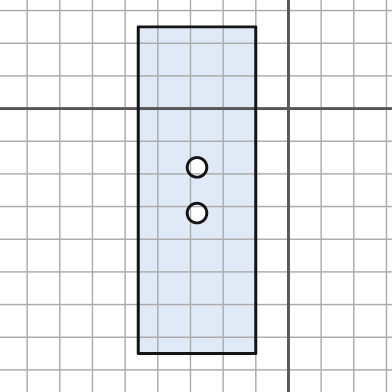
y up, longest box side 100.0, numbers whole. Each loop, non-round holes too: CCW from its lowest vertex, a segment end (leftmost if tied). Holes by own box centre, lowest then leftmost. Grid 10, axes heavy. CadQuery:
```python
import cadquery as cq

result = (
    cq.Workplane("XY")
    .moveTo(-46.0, -75.0)
    .lineTo(-10.0, -75.0)
    .lineTo(-10.0, 25.0)
    .lineTo(-46.0, 25.0)
    .close()
    .moveTo(-28.0, -32.0)
    .circle(3.0)
    .moveTo(-28.0, -18.0)
    .circle(3.0)
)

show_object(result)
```